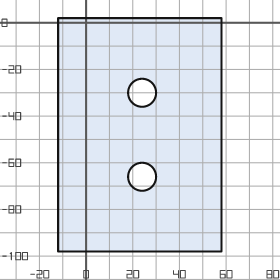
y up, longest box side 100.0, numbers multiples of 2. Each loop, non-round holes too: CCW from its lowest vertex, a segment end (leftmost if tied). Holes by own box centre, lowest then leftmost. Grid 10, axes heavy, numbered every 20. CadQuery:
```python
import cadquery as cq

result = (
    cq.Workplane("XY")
    .moveTo(-12.0, -98.0)
    .lineTo(58.0, -98.0)
    .lineTo(58.0, 2.0)
    .lineTo(-12.0, 2.0)
    .close()
    .moveTo(24.0, -66.0)
    .circle(6.0)
    .moveTo(24.0, -30.0)
    .circle(6.0)
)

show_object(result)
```